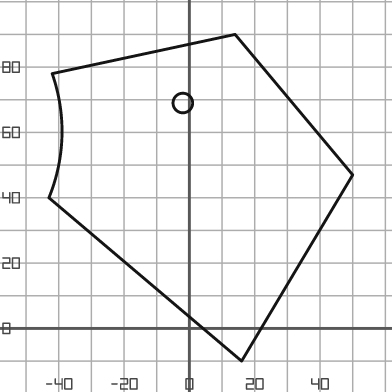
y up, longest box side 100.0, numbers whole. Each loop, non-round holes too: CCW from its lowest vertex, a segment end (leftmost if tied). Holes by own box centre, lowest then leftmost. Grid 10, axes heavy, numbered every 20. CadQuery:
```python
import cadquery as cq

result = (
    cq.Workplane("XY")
    .moveTo(16.0, -10.0)
    .lineTo(50.0, 47.0)
    .lineTo(14.0, 90.0)
    .lineTo(-42.0, 78.0)
    .threePointArc((-39.0, 59.0), (-43.0, 40.0))
    .close()
    .moveTo(-2.0, 69.0)
    .circle(3.0)
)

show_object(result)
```